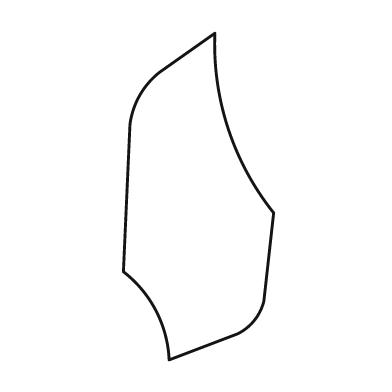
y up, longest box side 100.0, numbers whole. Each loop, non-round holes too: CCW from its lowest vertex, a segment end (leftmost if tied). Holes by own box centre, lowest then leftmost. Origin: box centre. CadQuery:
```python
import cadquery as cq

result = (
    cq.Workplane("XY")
    .moveTo(-9.0, -50.0)
    .lineTo(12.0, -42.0)
    .threePointArc((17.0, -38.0), (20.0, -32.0))
    .lineTo(23.0, -5.0)
    .threePointArc((9.0, 21.0), (5.0, 50.0))
    .lineTo(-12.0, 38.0)
    .threePointArc((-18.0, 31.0), (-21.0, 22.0))
    .lineTo(-23.0, -23.0)
    .threePointArc((-13.0, -35.0), (-9.0, -50.0))
    .close()
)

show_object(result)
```